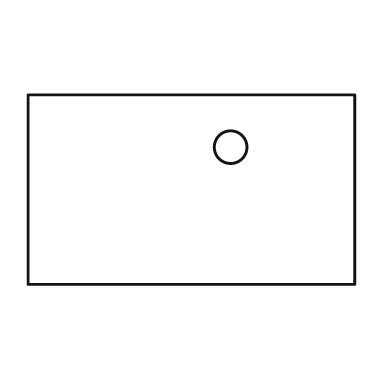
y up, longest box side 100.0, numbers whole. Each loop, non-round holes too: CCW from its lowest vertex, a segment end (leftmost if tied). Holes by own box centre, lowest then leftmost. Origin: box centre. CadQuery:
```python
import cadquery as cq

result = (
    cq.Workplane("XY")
    .moveTo(-50.0, -29.0)
    .lineTo(50.0, -29.0)
    .lineTo(50.0, 29.0)
    .lineTo(-50.0, 29.0)
    .close()
    .moveTo(12.0, 13.0)
    .circle(5.0)
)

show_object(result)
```